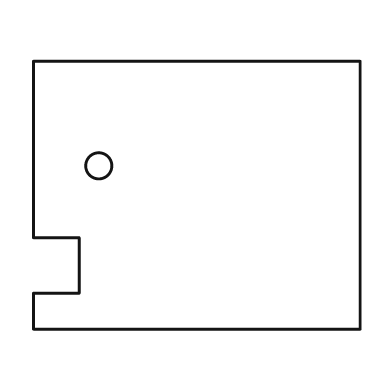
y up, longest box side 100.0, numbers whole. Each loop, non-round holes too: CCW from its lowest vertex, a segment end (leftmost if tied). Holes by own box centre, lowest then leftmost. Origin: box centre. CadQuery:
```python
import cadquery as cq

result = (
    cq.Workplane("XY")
    .moveTo(-50.0, -41.0)
    .lineTo(50.0, -41.0)
    .lineTo(50.0, 41.0)
    .lineTo(-50.0, 41.0)
    .lineTo(-50.0, -13.0)
    .lineTo(-36.0, -13.0)
    .lineTo(-36.0, -30.0)
    .lineTo(-50.0, -30.0)
    .close()
    .moveTo(-30.0, 9.0)
    .circle(4.0)
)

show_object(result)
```